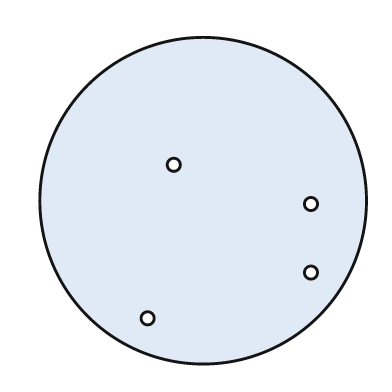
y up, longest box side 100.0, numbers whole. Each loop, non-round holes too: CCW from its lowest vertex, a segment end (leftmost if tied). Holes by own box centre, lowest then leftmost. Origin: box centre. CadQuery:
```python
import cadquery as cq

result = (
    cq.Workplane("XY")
    .moveTo(0.0, 0.0)
    .circle(50.0)
    .moveTo(-17.0, -36.0)
    .circle(2.0)
    .moveTo(33.0, -22.0)
    .circle(2.0)
    .moveTo(33.0, -1.0)
    .circle(2.0)
    .moveTo(-9.0, 11.0)
    .circle(2.0)
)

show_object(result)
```